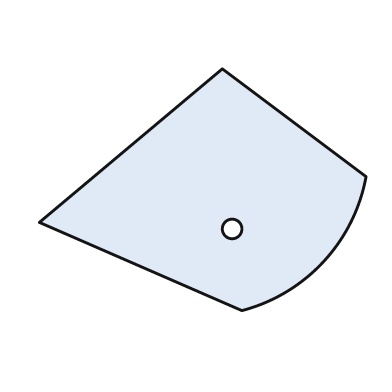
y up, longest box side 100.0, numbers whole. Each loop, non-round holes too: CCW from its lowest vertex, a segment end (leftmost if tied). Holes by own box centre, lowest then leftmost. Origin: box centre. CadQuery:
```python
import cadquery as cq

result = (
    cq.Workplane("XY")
    .moveTo(12.0, -37.0)
    .threePointArc((37.0, -22.0), (50.0, 4.0))
    .lineTo(6.0, 37.0)
    .lineTo(-50.0, -10.0)
    .close()
    .moveTo(9.0, -12.0)
    .circle(3.0)
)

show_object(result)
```